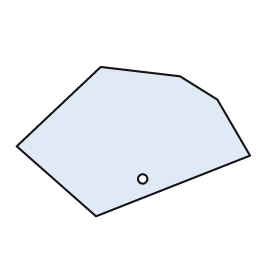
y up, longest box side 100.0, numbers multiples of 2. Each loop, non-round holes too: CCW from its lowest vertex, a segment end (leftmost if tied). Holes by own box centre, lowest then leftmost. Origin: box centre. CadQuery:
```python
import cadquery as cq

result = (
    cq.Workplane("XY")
    .moveTo(-16.0, -32.0)
    .lineTo(50.0, -6.0)
    .lineTo(36.0, 18.0)
    .lineTo(20.0, 28.0)
    .lineTo(-14.0, 32.0)
    .lineTo(-50.0, -2.0)
    .close()
    .moveTo(4.0, -16.0)
    .circle(2.0)
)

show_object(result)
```